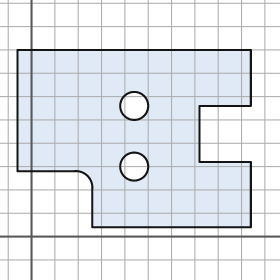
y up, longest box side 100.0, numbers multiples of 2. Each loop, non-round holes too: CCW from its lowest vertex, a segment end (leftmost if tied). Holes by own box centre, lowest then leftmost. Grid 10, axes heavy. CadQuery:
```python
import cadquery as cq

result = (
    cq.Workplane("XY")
    .moveTo(26.0, 4.0)
    .lineTo(94.0, 4.0)
    .lineTo(94.0, 32.0)
    .lineTo(72.0, 32.0)
    .lineTo(72.0, 56.0)
    .lineTo(94.0, 56.0)
    .lineTo(94.0, 80.0)
    .lineTo(-6.0, 80.0)
    .lineTo(-6.0, 28.0)
    .lineTo(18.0, 28.0)
    .threePointArc((24.0, 26.0), (26.0, 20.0))
    .close()
    .moveTo(44.0, 30.0)
    .circle(6.0)
    .moveTo(44.0, 56.0)
    .circle(6.0)
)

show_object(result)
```